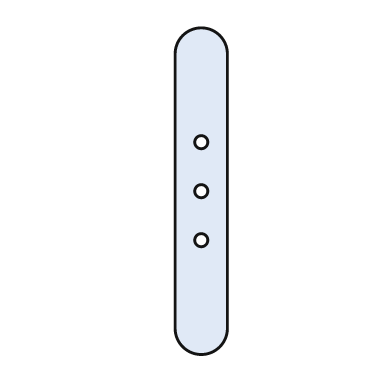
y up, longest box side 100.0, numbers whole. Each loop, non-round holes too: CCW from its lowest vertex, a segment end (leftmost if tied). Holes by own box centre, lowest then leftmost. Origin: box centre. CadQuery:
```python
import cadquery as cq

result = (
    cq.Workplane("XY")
    .moveTo(-8.0, -42.0)
    .threePointArc((0.0, -50.0), (8.0, -42.0))
    .lineTo(8.0, 42.0)
    .threePointArc((0.0, 50.0), (-8.0, 42.0))
    .close()
    .moveTo(0.0, -15.0)
    .circle(2.0)
    .moveTo(0.0, 0.0)
    .circle(2.0)
    .moveTo(0.0, 15.0)
    .circle(2.0)
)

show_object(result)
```